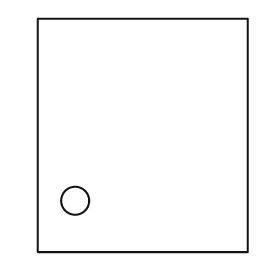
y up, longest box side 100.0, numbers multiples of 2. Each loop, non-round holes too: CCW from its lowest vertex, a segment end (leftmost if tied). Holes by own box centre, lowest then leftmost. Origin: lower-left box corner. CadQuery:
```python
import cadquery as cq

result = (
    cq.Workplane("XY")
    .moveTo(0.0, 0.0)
    .lineTo(90.0, 0.0)
    .lineTo(90.0, 100.0)
    .lineTo(0.0, 100.0)
    .close()
    .moveTo(16.0, 22.0)
    .circle(6.0)
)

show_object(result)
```